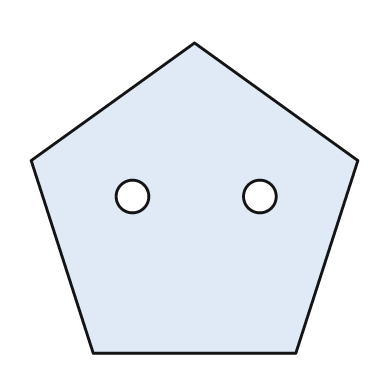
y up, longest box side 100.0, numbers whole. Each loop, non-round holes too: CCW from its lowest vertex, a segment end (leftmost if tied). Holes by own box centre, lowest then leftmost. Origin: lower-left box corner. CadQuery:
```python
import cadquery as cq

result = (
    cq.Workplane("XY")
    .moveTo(19.0, 0.0)
    .lineTo(81.0, 0.0)
    .lineTo(100.0, 59.0)
    .lineTo(50.0, 95.0)
    .lineTo(0.0, 59.0)
    .close()
    .moveTo(31.0, 48.0)
    .circle(5.0)
    .moveTo(70.0, 48.0)
    .circle(5.0)
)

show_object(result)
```